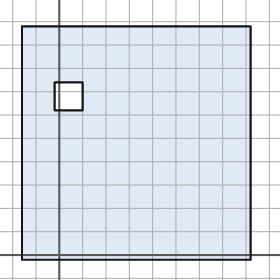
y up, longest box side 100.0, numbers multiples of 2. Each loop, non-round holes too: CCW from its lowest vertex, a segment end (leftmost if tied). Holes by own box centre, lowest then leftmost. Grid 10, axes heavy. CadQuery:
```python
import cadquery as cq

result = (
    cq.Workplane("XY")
    .moveTo(-16.0, -2.0)
    .lineTo(82.0, -2.0)
    .lineTo(82.0, 98.0)
    .lineTo(-16.0, 98.0)
    .close()
    .moveTo(-2.0, 62.0)
    .lineTo(10.0, 62.0)
    .lineTo(10.0, 74.0)
    .lineTo(-2.0, 74.0)
    .close()
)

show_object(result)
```